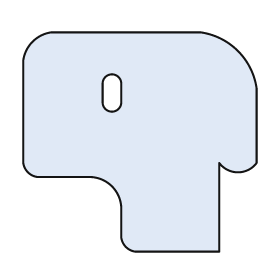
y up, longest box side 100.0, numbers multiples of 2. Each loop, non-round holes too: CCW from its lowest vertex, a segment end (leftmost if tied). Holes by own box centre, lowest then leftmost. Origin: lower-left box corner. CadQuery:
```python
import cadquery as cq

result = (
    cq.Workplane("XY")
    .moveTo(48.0, 0.0)
    .lineTo(84.0, 0.0)
    .lineTo(84.0, 38.0)
    .threePointArc((92.0, 34.0), (100.0, 38.0))
    .lineTo(100.0, 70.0)
    .threePointArc((92.0, 86.0), (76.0, 94.0))
    .lineTo(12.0, 94.0)
    .threePointArc((4.0, 90.0), (0.0, 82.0))
    .lineTo(0.0, 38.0)
    .threePointArc((2.0, 34.0), (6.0, 32.0))
    .lineTo(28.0, 32.0)
    .threePointArc((38.0, 28.0), (42.0, 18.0))
    .lineTo(42.0, 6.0)
    .threePointArc((44.0, 2.0), (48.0, 0.0))
    .close()
    .moveTo(34.0, 64.0)
    .threePointArc((38.0, 60.0), (42.0, 64.0))
    .lineTo(42.0, 72.0)
    .threePointArc((38.0, 76.0), (34.0, 72.0))
    .close()
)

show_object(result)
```